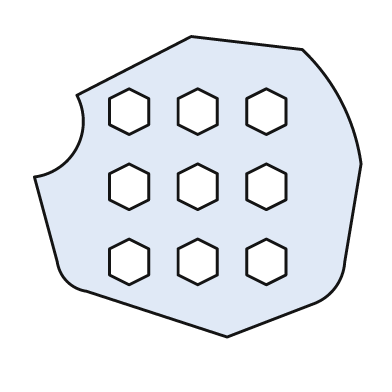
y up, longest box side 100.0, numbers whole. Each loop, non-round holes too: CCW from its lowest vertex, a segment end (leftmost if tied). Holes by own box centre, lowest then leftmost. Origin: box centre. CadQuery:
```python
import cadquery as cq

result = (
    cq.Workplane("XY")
    .moveTo(9.0, -46.0)
    .lineTo(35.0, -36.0)
    .threePointArc((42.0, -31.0), (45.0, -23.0))
    .lineTo(50.0, 7.0)
    .threePointArc((44.0, 26.0), (32.0, 42.0))
    .lineTo(-2.0, 46.0)
    .lineTo(-37.0, 28.0)
    .threePointArc((-37.0, 12.0), (-50.0, 3.0))
    .lineTo(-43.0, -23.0)
    .threePointArc((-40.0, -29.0), (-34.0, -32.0))
    .close()
    .moveTo(-21.0, -30.0)
    .lineTo(-15.0, -27.0)
    .lineTo(-15.0, -19.0)
    .lineTo(-21.0, -16.0)
    .lineTo(-27.0, -19.0)
    .lineTo(-27.0, -27.0)
    .close()
    .moveTo(0.0, -30.0)
    .lineTo(6.0, -27.0)
    .lineTo(6.0, -19.0)
    .lineTo(0.0, -16.0)
    .lineTo(-6.0, -19.0)
    .lineTo(-6.0, -27.0)
    .close()
    .moveTo(21.0, -30.0)
    .lineTo(27.0, -27.0)
    .lineTo(27.0, -19.0)
    .lineTo(21.0, -16.0)
    .lineTo(15.0, -19.0)
    .lineTo(15.0, -27.0)
    .close()
    .moveTo(-21.0, -7.0)
    .lineTo(-15.0, -4.0)
    .lineTo(-15.0, 4.0)
    .lineTo(-21.0, 7.0)
    .lineTo(-27.0, 4.0)
    .lineTo(-27.0, -4.0)
    .close()
    .moveTo(0.0, -7.0)
    .lineTo(6.0, -4.0)
    .lineTo(6.0, 4.0)
    .lineTo(0.0, 7.0)
    .lineTo(-6.0, 4.0)
    .lineTo(-6.0, -4.0)
    .close()
    .moveTo(21.0, -7.0)
    .lineTo(27.0, -4.0)
    .lineTo(27.0, 4.0)
    .lineTo(21.0, 7.0)
    .lineTo(15.0, 4.0)
    .lineTo(15.0, -4.0)
    .close()
    .moveTo(-21.0, 16.0)
    .lineTo(-15.0, 19.0)
    .lineTo(-15.0, 27.0)
    .lineTo(-21.0, 30.0)
    .lineTo(-27.0, 27.0)
    .lineTo(-27.0, 19.0)
    .close()
    .moveTo(0.0, 16.0)
    .lineTo(6.0, 19.0)
    .lineTo(6.0, 27.0)
    .lineTo(0.0, 30.0)
    .lineTo(-6.0, 27.0)
    .lineTo(-6.0, 19.0)
    .close()
    .moveTo(21.0, 16.0)
    .lineTo(27.0, 19.0)
    .lineTo(27.0, 27.0)
    .lineTo(21.0, 30.0)
    .lineTo(15.0, 27.0)
    .lineTo(15.0, 19.0)
    .close()
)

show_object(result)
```